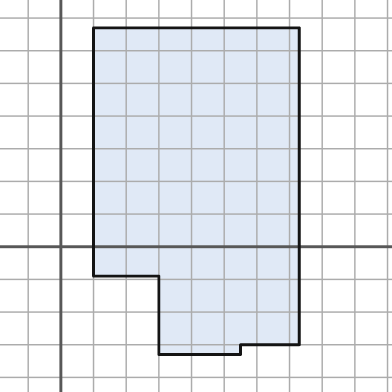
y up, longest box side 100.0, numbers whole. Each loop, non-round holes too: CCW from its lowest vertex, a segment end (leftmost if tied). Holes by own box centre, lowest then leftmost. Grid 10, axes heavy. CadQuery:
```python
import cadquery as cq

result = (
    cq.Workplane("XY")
    .moveTo(30.0, -33.0)
    .lineTo(55.0, -33.0)
    .lineTo(55.0, -30.0)
    .lineTo(73.0, -30.0)
    .lineTo(73.0, 67.0)
    .lineTo(10.0, 67.0)
    .lineTo(10.0, -9.0)
    .lineTo(30.0, -9.0)
    .close()
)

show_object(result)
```